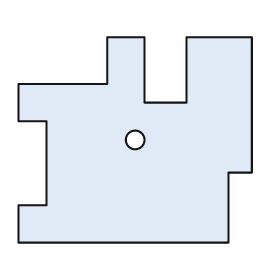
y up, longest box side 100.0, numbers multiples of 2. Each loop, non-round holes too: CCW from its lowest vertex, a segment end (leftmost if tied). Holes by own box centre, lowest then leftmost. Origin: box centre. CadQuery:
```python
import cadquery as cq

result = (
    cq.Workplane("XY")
    .moveTo(-50.0, -44.0)
    .lineTo(40.0, -44.0)
    .lineTo(40.0, -14.0)
    .lineTo(50.0, -14.0)
    .lineTo(50.0, 44.0)
    .lineTo(22.0, 44.0)
    .lineTo(22.0, 16.0)
    .lineTo(4.0, 16.0)
    .lineTo(4.0, 44.0)
    .lineTo(-12.0, 44.0)
    .lineTo(-12.0, 24.0)
    .lineTo(-50.0, 24.0)
    .lineTo(-50.0, 8.0)
    .lineTo(-38.0, 8.0)
    .lineTo(-38.0, -28.0)
    .lineTo(-50.0, -28.0)
    .close()
    .moveTo(0.0, 0.0)
    .circle(4.0)
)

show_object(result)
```